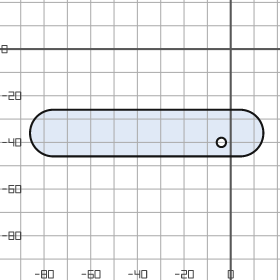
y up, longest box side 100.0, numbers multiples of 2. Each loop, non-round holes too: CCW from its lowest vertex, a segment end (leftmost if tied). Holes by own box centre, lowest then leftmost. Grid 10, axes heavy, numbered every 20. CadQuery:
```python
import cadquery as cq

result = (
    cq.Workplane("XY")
    .moveTo(-76.0, -46.0)
    .lineTo(4.0, -46.0)
    .threePointArc((14.0, -36.0), (4.0, -26.0))
    .lineTo(-76.0, -26.0)
    .threePointArc((-86.0, -36.0), (-76.0, -46.0))
    .close()
    .moveTo(-4.0, -40.0)
    .circle(2.0)
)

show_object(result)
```